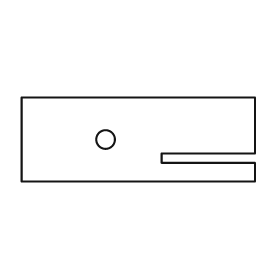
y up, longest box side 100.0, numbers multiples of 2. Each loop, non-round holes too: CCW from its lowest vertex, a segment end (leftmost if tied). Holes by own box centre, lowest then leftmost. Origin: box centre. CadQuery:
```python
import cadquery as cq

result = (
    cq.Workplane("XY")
    .moveTo(-50.0, -18.0)
    .lineTo(50.0, -18.0)
    .lineTo(50.0, -10.0)
    .lineTo(10.0, -10.0)
    .lineTo(10.0, -6.0)
    .lineTo(50.0, -6.0)
    .lineTo(50.0, 18.0)
    .lineTo(-50.0, 18.0)
    .close()
    .moveTo(-14.0, 0.0)
    .circle(4.0)
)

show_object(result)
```